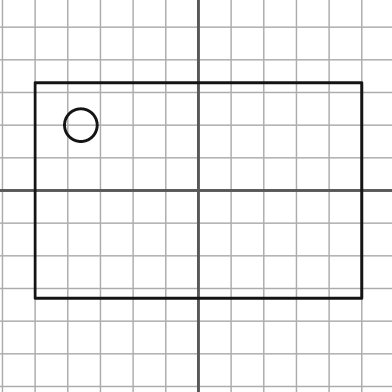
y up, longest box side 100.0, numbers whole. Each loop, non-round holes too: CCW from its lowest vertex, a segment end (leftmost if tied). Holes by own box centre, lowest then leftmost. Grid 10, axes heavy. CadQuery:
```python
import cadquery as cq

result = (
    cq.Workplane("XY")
    .moveTo(-50.0, -33.0)
    .lineTo(50.0, -33.0)
    .lineTo(50.0, 33.0)
    .lineTo(-50.0, 33.0)
    .close()
    .moveTo(-36.0, 20.0)
    .circle(5.0)
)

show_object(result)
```